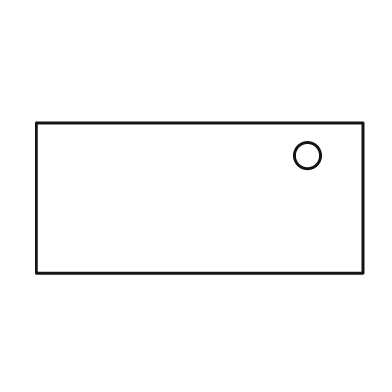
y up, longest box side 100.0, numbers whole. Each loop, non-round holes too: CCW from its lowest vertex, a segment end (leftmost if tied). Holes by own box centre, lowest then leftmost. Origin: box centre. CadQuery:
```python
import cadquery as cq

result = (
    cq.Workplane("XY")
    .moveTo(-50.0, -23.0)
    .lineTo(50.0, -23.0)
    .lineTo(50.0, 23.0)
    .lineTo(-50.0, 23.0)
    .close()
    .moveTo(33.0, 13.0)
    .circle(4.0)
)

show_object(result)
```